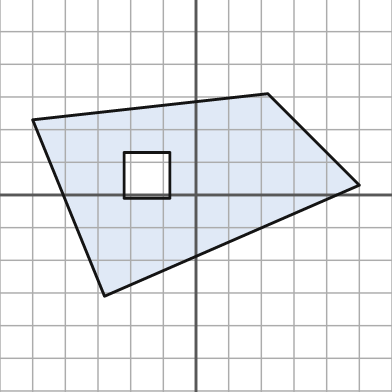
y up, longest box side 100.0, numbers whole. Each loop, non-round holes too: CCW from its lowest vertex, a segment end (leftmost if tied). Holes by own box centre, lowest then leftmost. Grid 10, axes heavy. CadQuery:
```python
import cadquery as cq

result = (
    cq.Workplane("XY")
    .moveTo(-28.0, -31.0)
    .lineTo(50.0, 3.0)
    .lineTo(22.0, 31.0)
    .lineTo(-50.0, 23.0)
    .close()
    .moveTo(-22.0, -1.0)
    .lineTo(-8.0, -1.0)
    .lineTo(-8.0, 13.0)
    .lineTo(-22.0, 13.0)
    .close()
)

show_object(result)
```